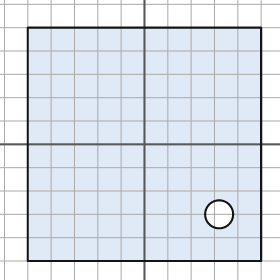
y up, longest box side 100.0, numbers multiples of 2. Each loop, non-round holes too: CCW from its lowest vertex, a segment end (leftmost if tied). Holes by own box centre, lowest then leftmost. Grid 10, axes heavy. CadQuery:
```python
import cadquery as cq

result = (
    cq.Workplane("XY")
    .moveTo(-50.0, -50.0)
    .lineTo(50.0, -50.0)
    .lineTo(50.0, 50.0)
    .lineTo(-50.0, 50.0)
    .close()
    .moveTo(32.0, -30.0)
    .circle(6.0)
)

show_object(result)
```